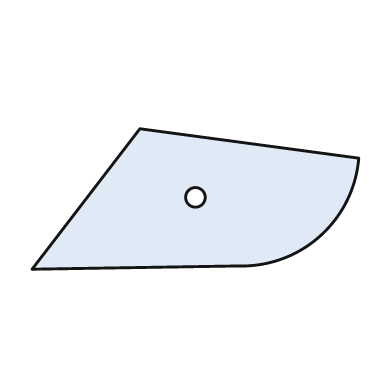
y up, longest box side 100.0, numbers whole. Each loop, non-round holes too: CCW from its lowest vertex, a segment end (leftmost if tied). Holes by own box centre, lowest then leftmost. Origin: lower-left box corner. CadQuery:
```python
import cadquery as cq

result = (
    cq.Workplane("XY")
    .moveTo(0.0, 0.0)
    .lineTo(63.0, 1.0)
    .threePointArc((88.0, 10.0), (100.0, 34.0))
    .lineTo(33.0, 43.0)
    .close()
    .moveTo(50.0, 22.0)
    .circle(3.0)
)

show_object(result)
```